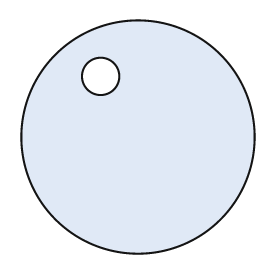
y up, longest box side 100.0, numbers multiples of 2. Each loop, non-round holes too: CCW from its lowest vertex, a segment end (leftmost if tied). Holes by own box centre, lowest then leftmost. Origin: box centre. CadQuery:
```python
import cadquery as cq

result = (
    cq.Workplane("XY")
    .moveTo(0.0, 0.0)
    .circle(50.0)
    .moveTo(-16.0, 26.0)
    .circle(8.0)
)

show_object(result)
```